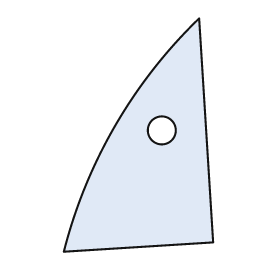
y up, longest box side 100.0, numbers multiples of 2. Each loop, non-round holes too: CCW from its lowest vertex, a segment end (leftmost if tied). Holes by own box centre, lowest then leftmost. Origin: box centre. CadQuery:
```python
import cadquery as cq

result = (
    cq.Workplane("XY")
    .moveTo(-32.0, -50.0)
    .lineTo(32.0, -46.0)
    .lineTo(26.0, 50.0)
    .threePointArc((-10.0, 4.0), (-32.0, -50.0))
    .close()
    .moveTo(10.0, 2.0)
    .circle(6.0)
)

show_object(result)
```